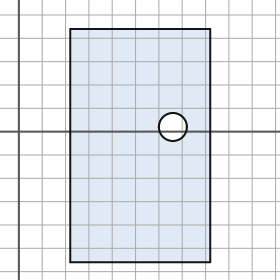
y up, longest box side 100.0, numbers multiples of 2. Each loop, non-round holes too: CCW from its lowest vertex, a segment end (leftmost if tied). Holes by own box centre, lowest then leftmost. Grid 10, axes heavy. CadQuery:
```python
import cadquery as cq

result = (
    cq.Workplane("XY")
    .moveTo(22.0, -56.0)
    .lineTo(82.0, -56.0)
    .lineTo(82.0, 44.0)
    .lineTo(22.0, 44.0)
    .close()
    .moveTo(66.0, 2.0)
    .circle(6.0)
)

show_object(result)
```